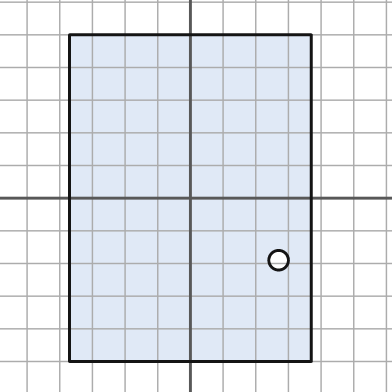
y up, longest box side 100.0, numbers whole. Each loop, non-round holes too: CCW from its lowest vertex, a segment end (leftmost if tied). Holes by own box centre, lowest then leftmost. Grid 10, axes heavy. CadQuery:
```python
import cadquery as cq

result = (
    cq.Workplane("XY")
    .moveTo(-37.0, -50.0)
    .lineTo(37.0, -50.0)
    .lineTo(37.0, 50.0)
    .lineTo(-37.0, 50.0)
    .close()
    .moveTo(27.0, -19.0)
    .circle(3.0)
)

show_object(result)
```